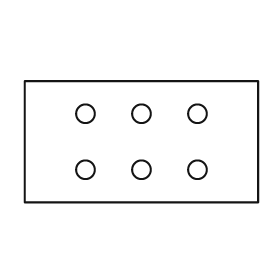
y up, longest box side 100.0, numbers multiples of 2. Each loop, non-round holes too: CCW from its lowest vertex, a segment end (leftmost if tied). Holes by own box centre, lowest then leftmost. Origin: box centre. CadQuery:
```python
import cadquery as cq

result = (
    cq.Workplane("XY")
    .moveTo(-50.0, -26.0)
    .lineTo(50.0, -26.0)
    .lineTo(50.0, 26.0)
    .lineTo(-50.0, 26.0)
    .close()
    .moveTo(-24.0, -12.0)
    .circle(4.0)
    .moveTo(0.0, -12.0)
    .circle(4.0)
    .moveTo(24.0, -12.0)
    .circle(4.0)
    .moveTo(-24.0, 12.0)
    .circle(4.0)
    .moveTo(0.0, 12.0)
    .circle(4.0)
    .moveTo(24.0, 12.0)
    .circle(4.0)
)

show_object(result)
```